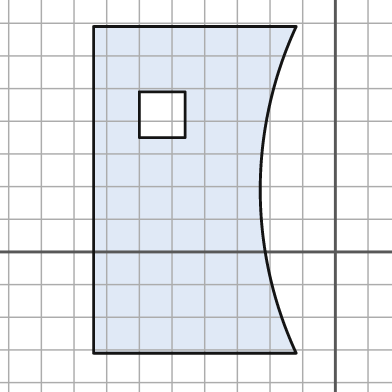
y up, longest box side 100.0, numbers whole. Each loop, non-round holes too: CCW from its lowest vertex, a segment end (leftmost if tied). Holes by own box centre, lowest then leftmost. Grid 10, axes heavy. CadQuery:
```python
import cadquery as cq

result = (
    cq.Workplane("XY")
    .moveTo(-74.0, -31.0)
    .lineTo(-12.0, -31.0)
    .threePointArc((-23.0, 19.0), (-12.0, 69.0))
    .lineTo(-74.0, 69.0)
    .close()
    .moveTo(-60.0, 35.0)
    .lineTo(-46.0, 35.0)
    .lineTo(-46.0, 49.0)
    .lineTo(-60.0, 49.0)
    .close()
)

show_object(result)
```